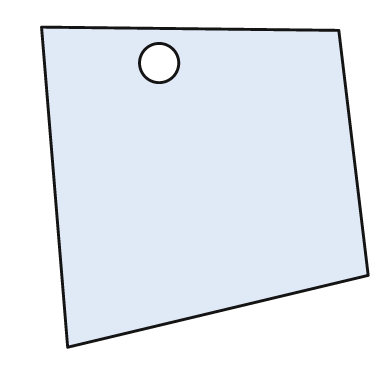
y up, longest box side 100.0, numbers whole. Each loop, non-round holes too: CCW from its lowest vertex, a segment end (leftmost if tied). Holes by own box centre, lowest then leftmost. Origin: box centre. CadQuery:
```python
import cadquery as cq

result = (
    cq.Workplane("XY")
    .moveTo(-42.0, -49.0)
    .lineTo(50.0, -27.0)
    .lineTo(41.0, 48.0)
    .lineTo(-50.0, 49.0)
    .close()
    .moveTo(-14.0, 38.0)
    .circle(6.0)
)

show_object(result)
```